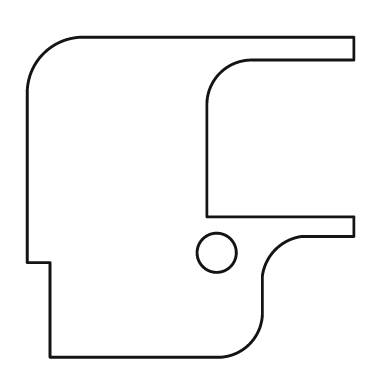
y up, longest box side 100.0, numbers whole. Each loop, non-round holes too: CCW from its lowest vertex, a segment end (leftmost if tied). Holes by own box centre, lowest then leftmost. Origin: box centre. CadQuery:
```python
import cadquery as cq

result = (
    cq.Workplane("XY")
    .moveTo(-43.0, -49.0)
    .lineTo(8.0, -49.0)
    .threePointArc((18.0, -45.0), (22.0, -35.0))
    .lineTo(22.0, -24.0)
    .threePointArc((26.0, -16.0), (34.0, -12.0))
    .lineTo(50.0, -12.0)
    .lineTo(50.0, -6.0)
    .lineTo(5.0, -6.0)
    .lineTo(5.0, 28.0)
    .threePointArc((9.0, 38.0), (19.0, 42.0))
    .lineTo(50.0, 42.0)
    .lineTo(50.0, 49.0)
    .lineTo(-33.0, 49.0)
    .threePointArc((-45.0, 44.0), (-50.0, 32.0))
    .lineTo(-50.0, -20.0)
    .lineTo(-43.0, -20.0)
    .close()
    .moveTo(8.0, -17.0)
    .circle(6.0)
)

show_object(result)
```